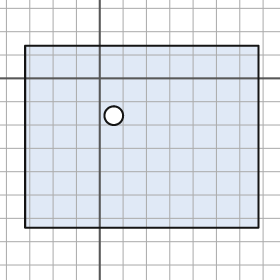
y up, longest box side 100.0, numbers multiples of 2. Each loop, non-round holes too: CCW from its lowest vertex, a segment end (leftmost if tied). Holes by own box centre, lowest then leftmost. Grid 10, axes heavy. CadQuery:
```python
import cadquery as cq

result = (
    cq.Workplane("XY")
    .moveTo(-32.0, -64.0)
    .lineTo(68.0, -64.0)
    .lineTo(68.0, 14.0)
    .lineTo(-32.0, 14.0)
    .close()
    .moveTo(6.0, -16.0)
    .circle(4.0)
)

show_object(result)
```